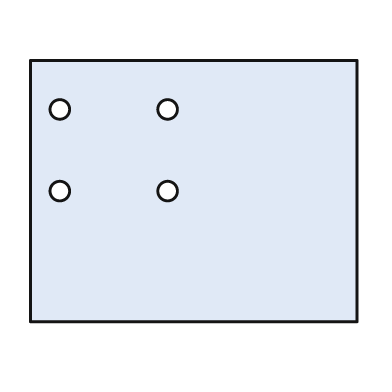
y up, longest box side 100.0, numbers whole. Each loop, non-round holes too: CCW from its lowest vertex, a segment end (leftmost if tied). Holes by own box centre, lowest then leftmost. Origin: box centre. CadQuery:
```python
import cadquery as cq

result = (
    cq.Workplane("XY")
    .moveTo(-50.0, -40.0)
    .lineTo(50.0, -40.0)
    .lineTo(50.0, 40.0)
    .lineTo(-50.0, 40.0)
    .close()
    .moveTo(-41.0, 0.0)
    .circle(3.0)
    .moveTo(-8.0, 0.0)
    .circle(3.0)
    .moveTo(-41.0, 25.0)
    .circle(3.0)
    .moveTo(-8.0, 25.0)
    .circle(3.0)
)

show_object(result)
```